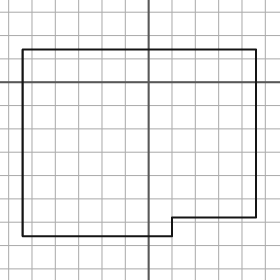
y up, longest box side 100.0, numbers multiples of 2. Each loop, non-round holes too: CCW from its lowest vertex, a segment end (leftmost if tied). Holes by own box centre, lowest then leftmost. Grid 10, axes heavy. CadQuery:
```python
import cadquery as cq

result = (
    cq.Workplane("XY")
    .moveTo(-54.0, -66.0)
    .lineTo(10.0, -66.0)
    .lineTo(10.0, -58.0)
    .lineTo(46.0, -58.0)
    .lineTo(46.0, 14.0)
    .lineTo(-54.0, 14.0)
    .close()
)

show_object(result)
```